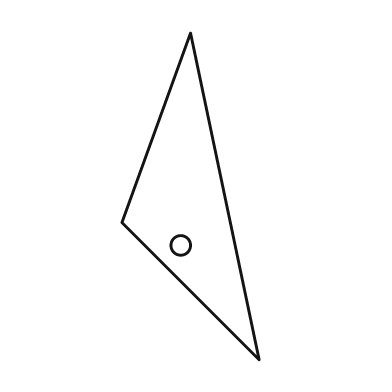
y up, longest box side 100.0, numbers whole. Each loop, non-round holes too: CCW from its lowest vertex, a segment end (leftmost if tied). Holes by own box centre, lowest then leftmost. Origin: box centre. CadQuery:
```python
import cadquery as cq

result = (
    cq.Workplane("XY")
    .moveTo(21.0, -50.0)
    .lineTo(0.0, 50.0)
    .lineTo(-21.0, -8.0)
    .close()
    .moveTo(-3.0, -15.0)
    .circle(3.0)
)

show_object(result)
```